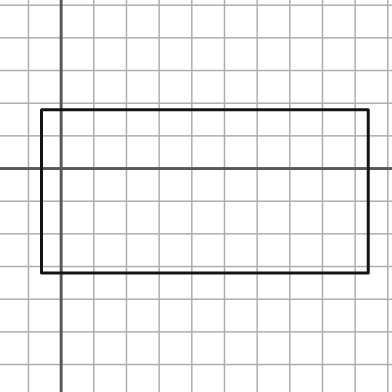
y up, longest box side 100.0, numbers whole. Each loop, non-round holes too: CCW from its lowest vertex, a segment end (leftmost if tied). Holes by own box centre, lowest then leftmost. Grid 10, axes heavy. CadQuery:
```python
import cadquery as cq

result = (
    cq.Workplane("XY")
    .moveTo(-6.0, -32.0)
    .lineTo(94.0, -32.0)
    .lineTo(94.0, 18.0)
    .lineTo(-6.0, 18.0)
    .close()
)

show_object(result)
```